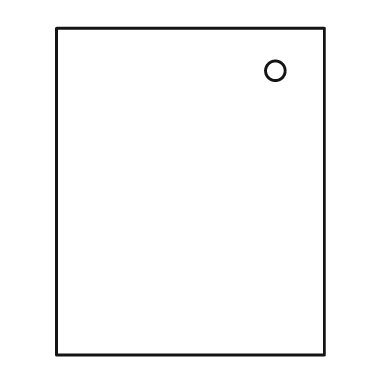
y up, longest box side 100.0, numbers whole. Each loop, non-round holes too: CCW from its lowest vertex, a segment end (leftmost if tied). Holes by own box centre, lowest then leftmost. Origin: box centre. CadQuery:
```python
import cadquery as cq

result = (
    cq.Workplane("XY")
    .moveTo(-41.0, -50.0)
    .lineTo(41.0, -50.0)
    .lineTo(41.0, 50.0)
    .lineTo(-41.0, 50.0)
    .close()
    .moveTo(26.0, 37.0)
    .circle(3.0)
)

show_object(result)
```